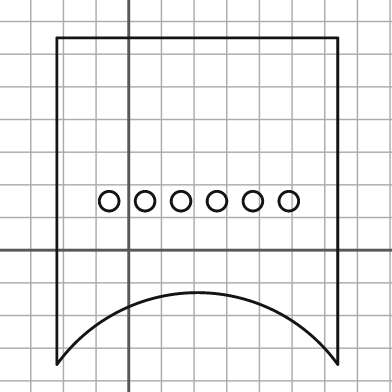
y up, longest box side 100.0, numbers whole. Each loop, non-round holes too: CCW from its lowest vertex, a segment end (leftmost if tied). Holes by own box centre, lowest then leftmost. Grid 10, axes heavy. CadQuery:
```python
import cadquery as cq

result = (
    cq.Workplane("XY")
    .moveTo(-22.0, -35.0)
    .threePointArc((21.0, -13.0), (64.0, -35.0))
    .lineTo(64.0, 65.0)
    .lineTo(-22.0, 65.0)
    .close()
    .moveTo(-6.0, 15.0)
    .circle(3.0)
    .moveTo(5.0, 15.0)
    .circle(3.0)
    .moveTo(16.0, 15.0)
    .circle(3.0)
    .moveTo(27.0, 15.0)
    .circle(3.0)
    .moveTo(38.0, 15.0)
    .circle(3.0)
    .moveTo(49.0, 15.0)
    .circle(3.0)
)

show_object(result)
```